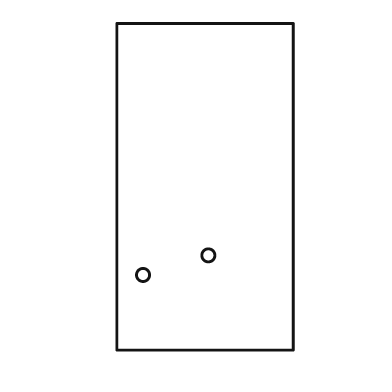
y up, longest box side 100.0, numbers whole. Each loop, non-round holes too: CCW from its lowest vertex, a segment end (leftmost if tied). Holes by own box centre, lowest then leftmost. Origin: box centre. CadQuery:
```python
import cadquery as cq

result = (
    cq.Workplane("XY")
    .moveTo(-27.0, -50.0)
    .lineTo(27.0, -50.0)
    .lineTo(27.0, 50.0)
    .lineTo(-27.0, 50.0)
    .close()
    .moveTo(-19.0, -27.0)
    .circle(2.0)
    .moveTo(1.0, -21.0)
    .circle(2.0)
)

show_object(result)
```